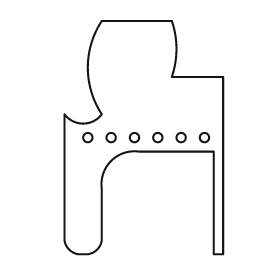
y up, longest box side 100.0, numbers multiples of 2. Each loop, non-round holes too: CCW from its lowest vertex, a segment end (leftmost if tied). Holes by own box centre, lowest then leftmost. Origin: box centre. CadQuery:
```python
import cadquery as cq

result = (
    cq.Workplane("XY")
    .moveTo(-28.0, -50.0)
    .lineTo(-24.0, -50.0)
    .threePointArc((-20.0, -48.0), (-18.0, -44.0))
    .lineTo(-18.0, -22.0)
    .threePointArc((-14.0, -10.0), (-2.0, -6.0))
    .lineTo(30.0, -6.0)
    .lineTo(30.0, -50.0)
    .lineTo(34.0, -50.0)
    .lineTo(34.0, 26.0)
    .lineTo(12.0, 26.0)
    .threePointArc((14.0, 38.0), (12.0, 50.0))
    .lineTo(-18.0, 50.0)
    .threePointArc((-24.0, 30.0), (-18.0, 10.0))
    .threePointArc((-26.0, 6.0), (-34.0, 10.0))
    .lineTo(-34.0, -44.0)
    .threePointArc((-32.0, -48.0), (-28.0, -50.0))
    .close()
    .moveTo(-24.0, 0.0)
    .circle(2.0)
    .moveTo(-14.0, 0.0)
    .circle(2.0)
    .moveTo(-4.0, 0.0)
    .circle(2.0)
    .moveTo(6.0, 0.0)
    .circle(2.0)
    .moveTo(16.0, 0.0)
    .circle(2.0)
    .moveTo(26.0, 0.0)
    .circle(2.0)
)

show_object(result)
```